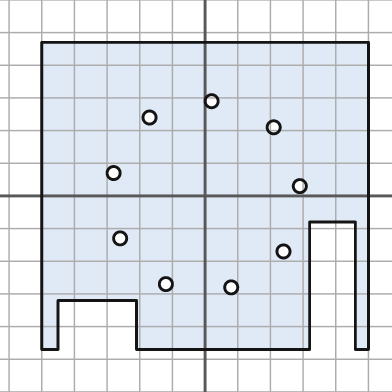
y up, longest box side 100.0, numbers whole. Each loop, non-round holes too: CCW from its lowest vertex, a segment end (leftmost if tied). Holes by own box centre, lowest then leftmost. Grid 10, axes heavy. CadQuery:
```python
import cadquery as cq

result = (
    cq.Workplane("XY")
    .moveTo(-50.0, -47.0)
    .lineTo(-45.0, -47.0)
    .lineTo(-45.0, -32.0)
    .lineTo(-21.0, -32.0)
    .lineTo(-21.0, -47.0)
    .lineTo(32.0, -47.0)
    .lineTo(32.0, -8.0)
    .lineTo(46.0, -8.0)
    .lineTo(46.0, -47.0)
    .lineTo(50.0, -47.0)
    .lineTo(50.0, 47.0)
    .lineTo(-50.0, 47.0)
    .close()
    .moveTo(8.0, -28.0)
    .circle(2.0)
    .moveTo(-12.0, -27.0)
    .circle(2.0)
    .moveTo(24.0, -17.0)
    .circle(2.0)
    .moveTo(-26.0, -13.0)
    .circle(2.0)
    .moveTo(29.0, 3.0)
    .circle(2.0)
    .moveTo(-28.0, 7.0)
    .circle(2.0)
    .moveTo(21.0, 21.0)
    .circle(2.0)
    .moveTo(-17.0, 24.0)
    .circle(2.0)
    .moveTo(2.0, 29.0)
    .circle(2.0)
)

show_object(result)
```